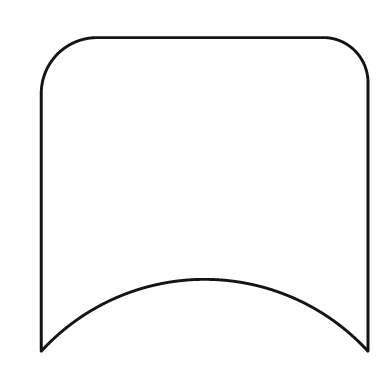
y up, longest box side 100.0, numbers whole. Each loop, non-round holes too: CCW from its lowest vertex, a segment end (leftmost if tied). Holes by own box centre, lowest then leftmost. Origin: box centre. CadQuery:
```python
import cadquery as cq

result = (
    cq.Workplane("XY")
    .moveTo(-50.0, -48.0)
    .threePointArc((0.0, -26.0), (50.0, -48.0))
    .lineTo(50.0, 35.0)
    .threePointArc((46.0, 44.0), (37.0, 48.0))
    .lineTo(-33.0, 48.0)
    .threePointArc((-45.0, 43.0), (-50.0, 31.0))
    .close()
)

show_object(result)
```